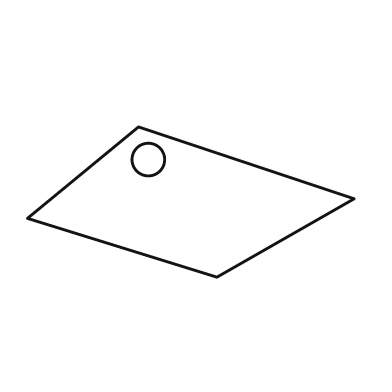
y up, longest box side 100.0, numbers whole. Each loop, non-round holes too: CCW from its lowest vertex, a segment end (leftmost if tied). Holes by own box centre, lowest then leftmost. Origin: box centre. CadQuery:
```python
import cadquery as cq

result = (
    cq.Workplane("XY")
    .moveTo(8.0, -23.0)
    .lineTo(50.0, 1.0)
    .lineTo(-16.0, 23.0)
    .lineTo(-50.0, -5.0)
    .close()
    .moveTo(-13.0, 13.0)
    .circle(5.0)
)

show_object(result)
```